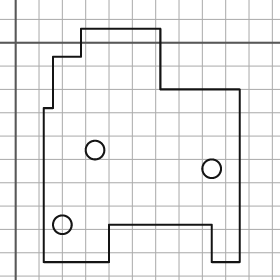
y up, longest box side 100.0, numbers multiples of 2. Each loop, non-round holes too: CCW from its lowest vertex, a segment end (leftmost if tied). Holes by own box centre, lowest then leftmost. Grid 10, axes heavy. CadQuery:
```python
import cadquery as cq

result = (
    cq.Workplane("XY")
    .moveTo(12.0, -94.0)
    .lineTo(40.0, -94.0)
    .lineTo(40.0, -78.0)
    .lineTo(84.0, -78.0)
    .lineTo(84.0, -94.0)
    .lineTo(96.0, -94.0)
    .lineTo(96.0, -20.0)
    .lineTo(62.0, -20.0)
    .lineTo(62.0, 6.0)
    .lineTo(28.0, 6.0)
    .lineTo(28.0, -6.0)
    .lineTo(16.0, -6.0)
    .lineTo(16.0, -28.0)
    .lineTo(12.0, -28.0)
    .close()
    .moveTo(20.0, -78.0)
    .circle(4.0)
    .moveTo(84.0, -54.0)
    .circle(4.0)
    .moveTo(34.0, -46.0)
    .circle(4.0)
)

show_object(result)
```